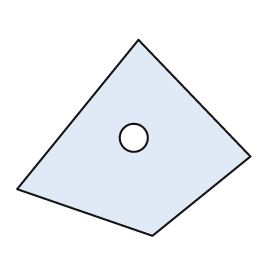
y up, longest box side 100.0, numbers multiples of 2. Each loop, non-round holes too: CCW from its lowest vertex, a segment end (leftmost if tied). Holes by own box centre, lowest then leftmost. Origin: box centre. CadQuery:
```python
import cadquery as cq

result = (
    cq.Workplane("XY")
    .moveTo(8.0, -42.0)
    .lineTo(50.0, -8.0)
    .lineTo(2.0, 42.0)
    .lineTo(-50.0, -22.0)
    .close()
    .moveTo(0.0, 0.0)
    .circle(6.0)
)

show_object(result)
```